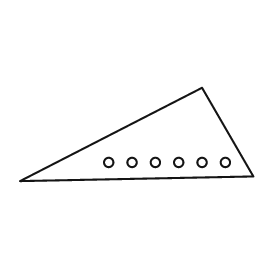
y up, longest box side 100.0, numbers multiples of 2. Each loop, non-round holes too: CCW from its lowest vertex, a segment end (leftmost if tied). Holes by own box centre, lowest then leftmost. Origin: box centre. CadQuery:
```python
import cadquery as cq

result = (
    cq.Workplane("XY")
    .moveTo(-50.0, -20.0)
    .lineTo(50.0, -18.0)
    .lineTo(28.0, 20.0)
    .close()
    .moveTo(-12.0, -12.0)
    .circle(2.0)
    .moveTo(-2.0, -12.0)
    .circle(2.0)
    .moveTo(8.0, -12.0)
    .circle(2.0)
    .moveTo(18.0, -12.0)
    .circle(2.0)
    .moveTo(28.0, -12.0)
    .circle(2.0)
    .moveTo(38.0, -12.0)
    .circle(2.0)
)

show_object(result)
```